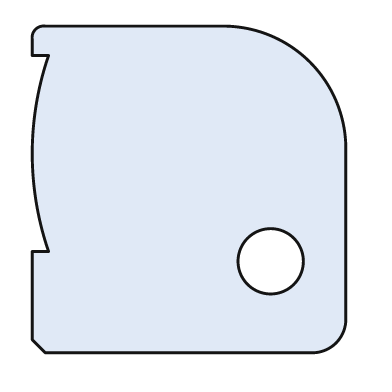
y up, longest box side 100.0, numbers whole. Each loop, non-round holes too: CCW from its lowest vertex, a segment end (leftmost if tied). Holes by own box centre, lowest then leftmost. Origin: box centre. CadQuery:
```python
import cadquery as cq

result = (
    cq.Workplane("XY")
    .moveTo(-44.0, -50.0)
    .lineTo(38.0, -50.0)
    .threePointArc((45.0, -47.0), (48.0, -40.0))
    .lineTo(48.0, 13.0)
    .threePointArc((37.0, 39.0), (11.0, 50.0))
    .lineTo(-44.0, 50.0)
    .threePointArc((-47.0, 49.0), (-48.0, 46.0))
    .lineTo(-48.0, 41.0)
    .lineTo(-43.0, 41.0)
    .threePointArc((-48.0, 11.0), (-43.0, -19.0))
    .lineTo(-48.0, -19.0)
    .lineTo(-48.0, -46.0)
    .close()
    .moveTo(25.0, -22.0)
    .circle(10.0)
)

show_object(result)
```